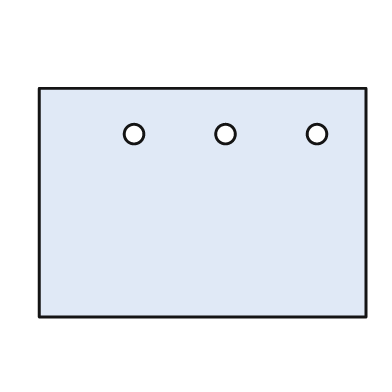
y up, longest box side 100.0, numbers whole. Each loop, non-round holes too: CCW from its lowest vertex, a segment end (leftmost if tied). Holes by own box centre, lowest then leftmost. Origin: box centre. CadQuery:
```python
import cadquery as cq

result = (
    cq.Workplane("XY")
    .moveTo(-50.0, -35.0)
    .lineTo(50.0, -35.0)
    .lineTo(50.0, 35.0)
    .lineTo(-50.0, 35.0)
    .close()
    .moveTo(-21.0, 21.0)
    .circle(3.0)
    .moveTo(7.0, 21.0)
    .circle(3.0)
    .moveTo(35.0, 21.0)
    .circle(3.0)
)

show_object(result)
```